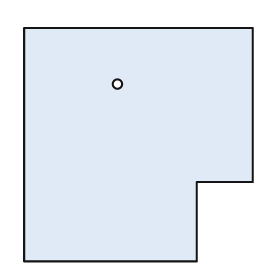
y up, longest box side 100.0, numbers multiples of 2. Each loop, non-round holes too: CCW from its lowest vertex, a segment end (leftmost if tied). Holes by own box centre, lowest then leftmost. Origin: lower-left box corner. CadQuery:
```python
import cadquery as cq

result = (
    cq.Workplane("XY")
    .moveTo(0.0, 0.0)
    .lineTo(74.0, 0.0)
    .lineTo(74.0, 34.0)
    .lineTo(98.0, 34.0)
    .lineTo(98.0, 100.0)
    .lineTo(0.0, 100.0)
    .close()
    .moveTo(40.0, 76.0)
    .circle(2.0)
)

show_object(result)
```